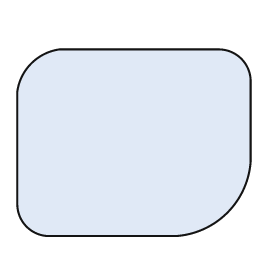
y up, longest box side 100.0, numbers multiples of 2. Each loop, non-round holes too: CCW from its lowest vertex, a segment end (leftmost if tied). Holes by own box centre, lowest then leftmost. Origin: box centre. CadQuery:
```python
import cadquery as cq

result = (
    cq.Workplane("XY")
    .moveTo(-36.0, -40.0)
    .lineTo(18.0, -40.0)
    .threePointArc((40.0, -30.0), (50.0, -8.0))
    .lineTo(50.0, 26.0)
    .threePointArc((46.0, 36.0), (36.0, 40.0))
    .lineTo(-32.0, 40.0)
    .threePointArc((-44.0, 34.0), (-50.0, 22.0))
    .lineTo(-50.0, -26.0)
    .threePointArc((-46.0, -36.0), (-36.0, -40.0))
    .close()
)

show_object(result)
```